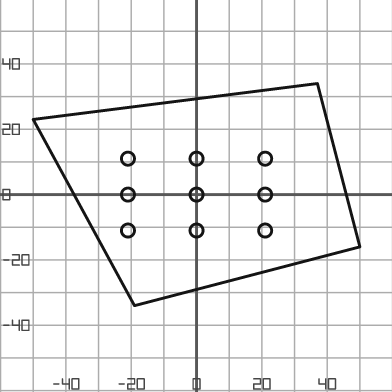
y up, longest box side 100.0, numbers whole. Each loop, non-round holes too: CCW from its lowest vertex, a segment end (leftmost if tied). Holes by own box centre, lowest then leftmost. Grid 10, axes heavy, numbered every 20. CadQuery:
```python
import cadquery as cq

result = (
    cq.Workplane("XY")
    .moveTo(-19.0, -34.0)
    .lineTo(50.0, -16.0)
    .lineTo(37.0, 34.0)
    .lineTo(-50.0, 23.0)
    .close()
    .moveTo(-21.0, -11.0)
    .circle(2.0)
    .moveTo(0.0, -11.0)
    .circle(2.0)
    .moveTo(21.0, -11.0)
    .circle(2.0)
    .moveTo(-21.0, 0.0)
    .circle(2.0)
    .moveTo(0.0, 0.0)
    .circle(2.0)
    .moveTo(21.0, 0.0)
    .circle(2.0)
    .moveTo(-21.0, 11.0)
    .circle(2.0)
    .moveTo(0.0, 11.0)
    .circle(2.0)
    .moveTo(21.0, 11.0)
    .circle(2.0)
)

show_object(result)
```